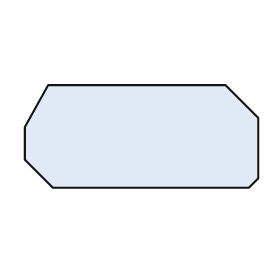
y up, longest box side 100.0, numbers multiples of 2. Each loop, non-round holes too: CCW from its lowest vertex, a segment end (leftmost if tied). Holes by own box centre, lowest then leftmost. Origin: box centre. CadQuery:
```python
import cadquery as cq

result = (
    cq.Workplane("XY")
    .moveTo(-38.0, -22.0)
    .lineTo(46.0, -22.0)
    .lineTo(50.0, -18.0)
    .lineTo(50.0, 8.0)
    .lineTo(36.0, 22.0)
    .lineTo(-40.0, 22.0)
    .lineTo(-50.0, 4.0)
    .lineTo(-50.0, -10.0)
    .close()
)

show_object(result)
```